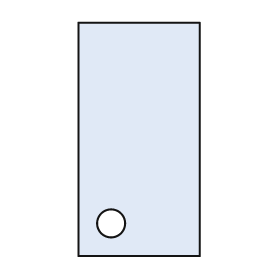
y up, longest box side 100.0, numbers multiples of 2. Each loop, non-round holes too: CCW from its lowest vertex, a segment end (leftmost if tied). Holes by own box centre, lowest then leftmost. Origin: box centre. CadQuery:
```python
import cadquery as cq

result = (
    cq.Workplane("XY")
    .moveTo(-26.0, -50.0)
    .lineTo(26.0, -50.0)
    .lineTo(26.0, 50.0)
    .lineTo(-26.0, 50.0)
    .close()
    .moveTo(-12.0, -36.0)
    .circle(6.0)
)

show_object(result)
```